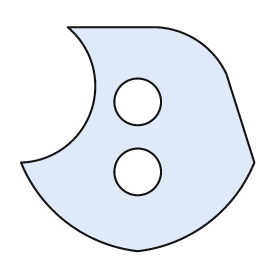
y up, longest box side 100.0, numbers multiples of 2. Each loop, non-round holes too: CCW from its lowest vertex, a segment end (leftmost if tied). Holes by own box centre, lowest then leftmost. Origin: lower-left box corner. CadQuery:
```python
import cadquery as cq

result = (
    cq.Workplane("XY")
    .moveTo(50.0, 0.0)
    .threePointArc((80.0, 12.0), (100.0, 38.0))
    .lineTo(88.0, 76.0)
    .threePointArc((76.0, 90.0), (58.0, 96.0))
    .lineTo(20.0, 96.0)
    .threePointArc((30.0, 60.0), (0.0, 38.0))
    .threePointArc((20.0, 12.0), (50.0, 0.0))
    .close()
    .moveTo(50.0, 34.0)
    .circle(10.0)
    .moveTo(50.0, 64.0)
    .circle(10.0)
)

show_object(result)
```